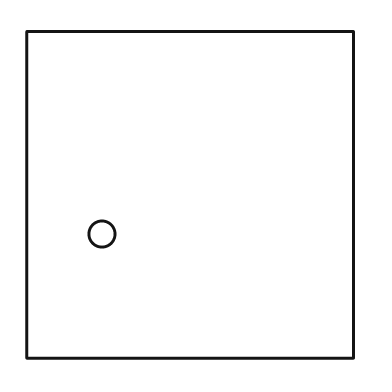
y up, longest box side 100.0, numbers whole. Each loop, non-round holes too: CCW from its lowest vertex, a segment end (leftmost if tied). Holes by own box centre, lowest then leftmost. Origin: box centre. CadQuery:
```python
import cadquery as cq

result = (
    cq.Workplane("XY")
    .moveTo(-50.0, -50.0)
    .lineTo(50.0, -50.0)
    .lineTo(50.0, 50.0)
    .lineTo(-50.0, 50.0)
    .close()
    .moveTo(-27.0, -12.0)
    .circle(4.0)
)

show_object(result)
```